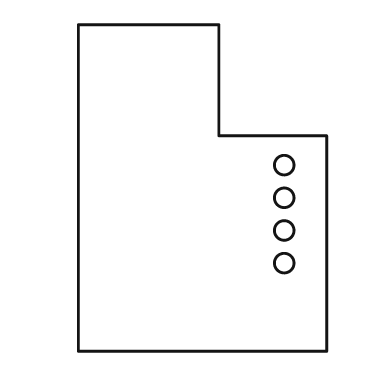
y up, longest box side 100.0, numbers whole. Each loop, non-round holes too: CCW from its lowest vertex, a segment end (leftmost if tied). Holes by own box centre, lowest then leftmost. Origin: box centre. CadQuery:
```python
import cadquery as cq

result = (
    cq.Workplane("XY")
    .moveTo(-38.0, -50.0)
    .lineTo(38.0, -50.0)
    .lineTo(38.0, 16.0)
    .lineTo(5.0, 16.0)
    .lineTo(5.0, 50.0)
    .lineTo(-38.0, 50.0)
    .close()
    .moveTo(25.0, -23.0)
    .circle(3.0)
    .moveTo(25.0, -13.0)
    .circle(3.0)
    .moveTo(25.0, -3.0)
    .circle(3.0)
    .moveTo(25.0, 7.0)
    .circle(3.0)
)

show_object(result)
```